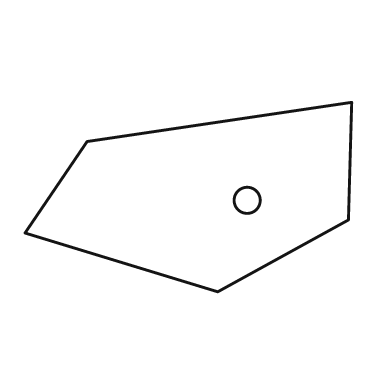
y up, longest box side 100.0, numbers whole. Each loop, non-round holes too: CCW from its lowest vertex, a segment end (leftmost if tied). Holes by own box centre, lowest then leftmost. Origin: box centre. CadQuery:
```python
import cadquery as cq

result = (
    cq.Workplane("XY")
    .moveTo(9.0, -29.0)
    .lineTo(49.0, -7.0)
    .lineTo(50.0, 29.0)
    .lineTo(-31.0, 17.0)
    .lineTo(-50.0, -11.0)
    .close()
    .moveTo(18.0, -1.0)
    .circle(4.0)
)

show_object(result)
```